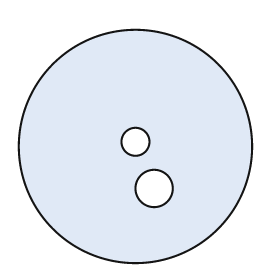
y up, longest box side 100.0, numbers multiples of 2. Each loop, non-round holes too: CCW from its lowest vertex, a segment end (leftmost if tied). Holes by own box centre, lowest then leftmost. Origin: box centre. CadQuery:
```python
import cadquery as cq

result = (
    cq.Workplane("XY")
    .moveTo(0.0, 0.0)
    .circle(50.0)
    .moveTo(8.0, -18.0)
    .circle(8.0)
    .moveTo(0.0, 2.0)
    .circle(6.0)
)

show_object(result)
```